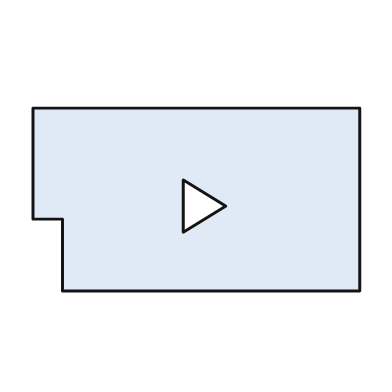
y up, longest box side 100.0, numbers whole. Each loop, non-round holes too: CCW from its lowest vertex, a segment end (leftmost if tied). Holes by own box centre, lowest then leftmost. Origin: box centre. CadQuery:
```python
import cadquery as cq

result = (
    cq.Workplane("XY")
    .moveTo(-41.0, -28.0)
    .lineTo(50.0, -28.0)
    .lineTo(50.0, 28.0)
    .lineTo(-50.0, 28.0)
    .lineTo(-50.0, -6.0)
    .lineTo(-41.0, -6.0)
    .close()
    .moveTo(-4.0, -10.0)
    .lineTo(9.0, -2.0)
    .lineTo(-4.0, 6.0)
    .close()
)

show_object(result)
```